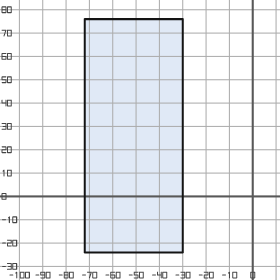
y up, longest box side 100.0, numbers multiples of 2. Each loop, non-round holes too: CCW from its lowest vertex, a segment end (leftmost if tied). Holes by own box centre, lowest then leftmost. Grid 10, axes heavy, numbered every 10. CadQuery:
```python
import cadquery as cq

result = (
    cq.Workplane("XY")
    .moveTo(-72.0, -24.0)
    .lineTo(-30.0, -24.0)
    .lineTo(-30.0, 76.0)
    .lineTo(-72.0, 76.0)
    .close()
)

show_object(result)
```